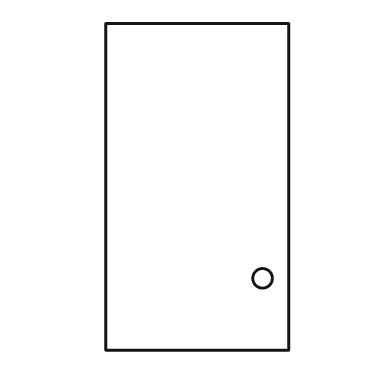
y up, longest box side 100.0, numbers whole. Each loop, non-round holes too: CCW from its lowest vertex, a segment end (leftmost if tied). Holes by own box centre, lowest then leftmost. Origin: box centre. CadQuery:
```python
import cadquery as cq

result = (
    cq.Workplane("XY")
    .moveTo(-28.0, -50.0)
    .lineTo(28.0, -50.0)
    .lineTo(28.0, 50.0)
    .lineTo(-28.0, 50.0)
    .close()
    .moveTo(20.0, -28.0)
    .circle(3.0)
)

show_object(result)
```